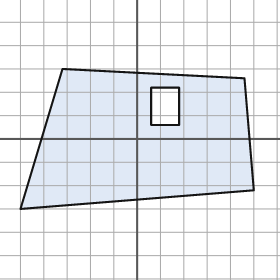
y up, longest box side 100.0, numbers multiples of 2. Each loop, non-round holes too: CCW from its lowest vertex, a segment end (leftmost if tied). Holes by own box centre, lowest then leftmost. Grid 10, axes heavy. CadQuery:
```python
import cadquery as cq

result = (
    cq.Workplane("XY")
    .moveTo(-50.0, -30.0)
    .lineTo(50.0, -22.0)
    .lineTo(46.0, 26.0)
    .lineTo(-32.0, 30.0)
    .close()
    .moveTo(6.0, 6.0)
    .lineTo(18.0, 6.0)
    .lineTo(18.0, 22.0)
    .lineTo(6.0, 22.0)
    .close()
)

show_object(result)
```